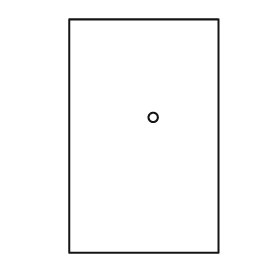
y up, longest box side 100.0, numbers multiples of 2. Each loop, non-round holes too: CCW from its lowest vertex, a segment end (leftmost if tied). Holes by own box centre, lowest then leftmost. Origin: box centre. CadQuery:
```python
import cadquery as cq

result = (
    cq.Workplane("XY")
    .moveTo(-32.0, -50.0)
    .lineTo(32.0, -50.0)
    .lineTo(32.0, 50.0)
    .lineTo(-32.0, 50.0)
    .close()
    .moveTo(4.0, 8.0)
    .circle(2.0)
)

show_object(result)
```